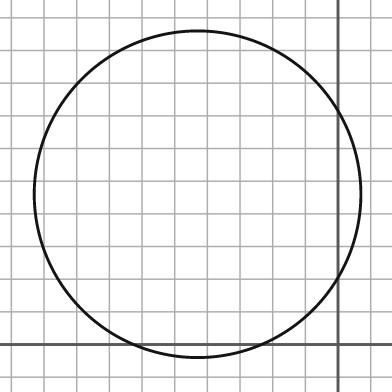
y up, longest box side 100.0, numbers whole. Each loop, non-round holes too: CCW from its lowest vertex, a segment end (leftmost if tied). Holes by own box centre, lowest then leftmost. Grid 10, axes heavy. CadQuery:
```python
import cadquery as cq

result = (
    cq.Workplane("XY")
    .moveTo(-43.0, 46.0)
    .circle(50.0)
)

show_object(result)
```